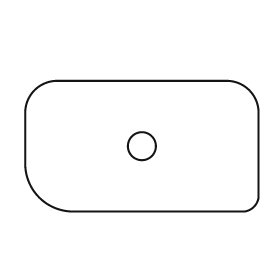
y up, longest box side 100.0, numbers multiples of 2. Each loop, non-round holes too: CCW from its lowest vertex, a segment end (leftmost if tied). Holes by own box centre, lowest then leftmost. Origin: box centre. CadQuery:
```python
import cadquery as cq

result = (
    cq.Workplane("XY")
    .moveTo(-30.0, -28.0)
    .lineTo(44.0, -28.0)
    .threePointArc((48.0, -26.0), (50.0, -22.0))
    .lineTo(50.0, 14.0)
    .threePointArc((46.0, 24.0), (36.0, 28.0))
    .lineTo(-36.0, 28.0)
    .threePointArc((-46.0, 24.0), (-50.0, 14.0))
    .lineTo(-50.0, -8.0)
    .threePointArc((-44.0, -22.0), (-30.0, -28.0))
    .close()
    .moveTo(0.0, 0.0)
    .circle(6.0)
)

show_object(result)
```